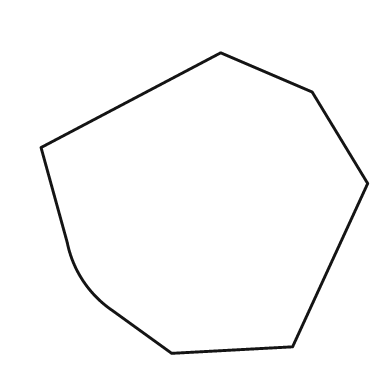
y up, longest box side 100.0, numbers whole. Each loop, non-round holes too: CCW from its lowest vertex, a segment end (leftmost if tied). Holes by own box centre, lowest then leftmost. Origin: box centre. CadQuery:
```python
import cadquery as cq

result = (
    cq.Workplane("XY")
    .moveTo(-10.0, -46.0)
    .lineTo(27.0, -44.0)
    .lineTo(50.0, 6.0)
    .lineTo(33.0, 34.0)
    .lineTo(5.0, 46.0)
    .lineTo(-50.0, 17.0)
    .lineTo(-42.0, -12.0)
    .threePointArc((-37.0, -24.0), (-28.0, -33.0))
    .close()
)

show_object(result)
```